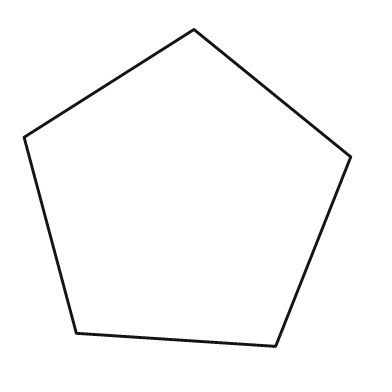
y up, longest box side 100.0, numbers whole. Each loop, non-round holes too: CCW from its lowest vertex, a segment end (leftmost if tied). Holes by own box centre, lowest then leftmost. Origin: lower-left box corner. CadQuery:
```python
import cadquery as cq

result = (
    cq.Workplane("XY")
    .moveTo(77.0, 0.0)
    .lineTo(100.0, 58.0)
    .lineTo(52.0, 97.0)
    .lineTo(0.0, 64.0)
    .lineTo(16.0, 4.0)
    .close()
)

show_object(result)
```